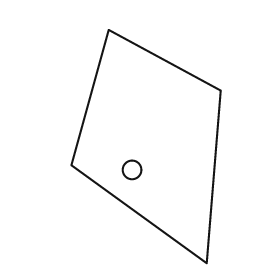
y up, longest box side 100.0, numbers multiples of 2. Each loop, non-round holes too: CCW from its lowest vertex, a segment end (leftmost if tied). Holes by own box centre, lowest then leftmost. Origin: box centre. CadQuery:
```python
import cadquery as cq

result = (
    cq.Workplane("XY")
    .moveTo(26.0, -50.0)
    .lineTo(32.0, 24.0)
    .lineTo(-16.0, 50.0)
    .lineTo(-32.0, -8.0)
    .close()
    .moveTo(-6.0, -10.0)
    .circle(4.0)
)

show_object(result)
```